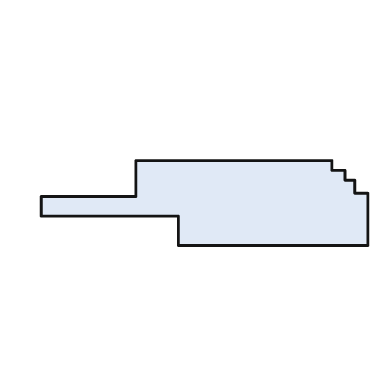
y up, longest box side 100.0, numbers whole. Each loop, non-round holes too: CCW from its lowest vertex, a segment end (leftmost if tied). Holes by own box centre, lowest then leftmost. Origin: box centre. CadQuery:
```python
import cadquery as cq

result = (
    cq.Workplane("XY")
    .moveTo(-8.0, -13.0)
    .lineTo(50.0, -13.0)
    .lineTo(50.0, 3.0)
    .lineTo(46.0, 3.0)
    .lineTo(46.0, 7.0)
    .lineTo(43.0, 7.0)
    .lineTo(43.0, 10.0)
    .lineTo(39.0, 10.0)
    .lineTo(39.0, 13.0)
    .lineTo(-21.0, 13.0)
    .lineTo(-21.0, 2.0)
    .lineTo(-50.0, 2.0)
    .lineTo(-50.0, -4.0)
    .lineTo(-8.0, -4.0)
    .close()
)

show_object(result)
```